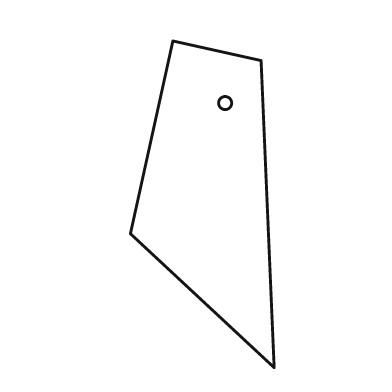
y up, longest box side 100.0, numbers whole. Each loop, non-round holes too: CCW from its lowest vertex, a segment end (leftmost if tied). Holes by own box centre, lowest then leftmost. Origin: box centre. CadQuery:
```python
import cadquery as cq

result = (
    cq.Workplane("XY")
    .moveTo(22.0, -50.0)
    .lineTo(18.0, 44.0)
    .lineTo(-9.0, 50.0)
    .lineTo(-22.0, -9.0)
    .close()
    .moveTo(7.0, 31.0)
    .circle(2.0)
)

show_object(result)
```